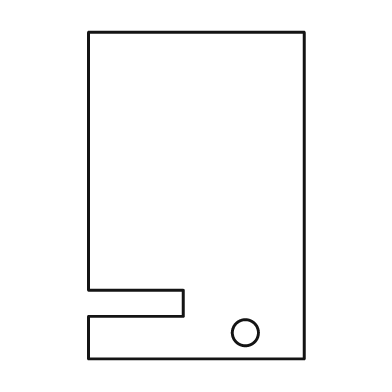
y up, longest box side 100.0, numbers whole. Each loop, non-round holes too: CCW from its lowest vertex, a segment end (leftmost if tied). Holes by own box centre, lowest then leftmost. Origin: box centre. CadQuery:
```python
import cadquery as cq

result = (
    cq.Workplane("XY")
    .moveTo(-33.0, -50.0)
    .lineTo(33.0, -50.0)
    .lineTo(33.0, 50.0)
    .lineTo(-33.0, 50.0)
    .lineTo(-33.0, -29.0)
    .lineTo(-4.0, -29.0)
    .lineTo(-4.0, -37.0)
    .lineTo(-33.0, -37.0)
    .close()
    .moveTo(15.0, -42.0)
    .circle(4.0)
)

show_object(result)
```